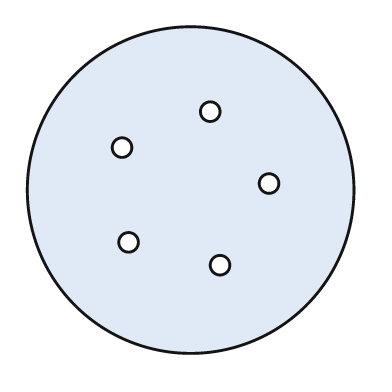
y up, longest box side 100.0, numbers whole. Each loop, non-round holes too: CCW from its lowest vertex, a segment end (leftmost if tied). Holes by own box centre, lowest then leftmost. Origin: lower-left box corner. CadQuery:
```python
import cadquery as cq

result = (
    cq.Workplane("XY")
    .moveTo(50.0, 50.0)
    .circle(50.0)
    .moveTo(59.0, 27.0)
    .circle(3.0)
    .moveTo(31.0, 34.0)
    .circle(3.0)
    .moveTo(74.0, 52.0)
    .circle(3.0)
    .moveTo(29.0, 63.0)
    .circle(3.0)
    .moveTo(56.0, 74.0)
    .circle(3.0)
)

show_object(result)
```